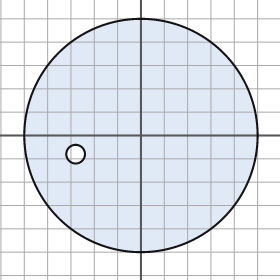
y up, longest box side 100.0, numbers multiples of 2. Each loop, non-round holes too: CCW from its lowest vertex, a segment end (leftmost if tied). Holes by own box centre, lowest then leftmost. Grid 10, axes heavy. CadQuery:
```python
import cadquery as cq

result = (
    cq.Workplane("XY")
    .moveTo(0.0, 0.0)
    .circle(50.0)
    .moveTo(-28.0, -8.0)
    .circle(4.0)
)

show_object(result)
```